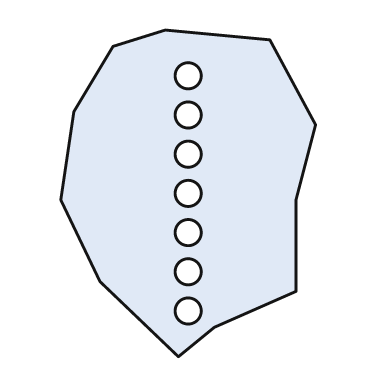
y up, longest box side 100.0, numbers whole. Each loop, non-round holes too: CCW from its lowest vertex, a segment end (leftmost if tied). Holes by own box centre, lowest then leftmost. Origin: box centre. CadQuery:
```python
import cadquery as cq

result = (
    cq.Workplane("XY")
    .moveTo(-3.0, -50.0)
    .lineTo(8.0, -41.0)
    .lineTo(33.0, -30.0)
    .lineTo(33.0, -2.0)
    .lineTo(39.0, 21.0)
    .lineTo(25.0, 47.0)
    .lineTo(-7.0, 50.0)
    .lineTo(-23.0, 45.0)
    .lineTo(-35.0, 25.0)
    .lineTo(-39.0, -2.0)
    .lineTo(-27.0, -27.0)
    .close()
    .moveTo(0.0, -36.0)
    .circle(4.0)
    .moveTo(0.0, -24.0)
    .circle(4.0)
    .moveTo(0.0, -12.0)
    .circle(4.0)
    .moveTo(0.0, 0.0)
    .circle(4.0)
    .moveTo(0.0, 12.0)
    .circle(4.0)
    .moveTo(0.0, 24.0)
    .circle(4.0)
    .moveTo(0.0, 36.0)
    .circle(4.0)
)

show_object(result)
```